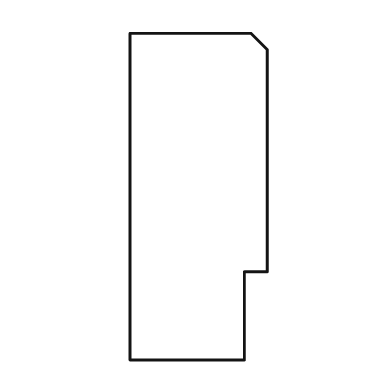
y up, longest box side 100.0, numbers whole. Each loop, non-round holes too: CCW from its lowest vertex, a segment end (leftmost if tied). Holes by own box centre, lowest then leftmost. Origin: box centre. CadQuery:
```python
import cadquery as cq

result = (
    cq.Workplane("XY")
    .moveTo(-21.0, -50.0)
    .lineTo(14.0, -50.0)
    .lineTo(14.0, -23.0)
    .lineTo(21.0, -23.0)
    .lineTo(21.0, 45.0)
    .lineTo(16.0, 50.0)
    .lineTo(-21.0, 50.0)
    .close()
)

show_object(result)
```